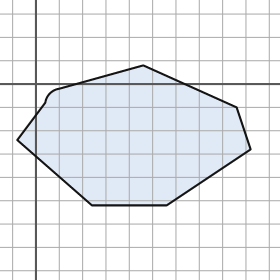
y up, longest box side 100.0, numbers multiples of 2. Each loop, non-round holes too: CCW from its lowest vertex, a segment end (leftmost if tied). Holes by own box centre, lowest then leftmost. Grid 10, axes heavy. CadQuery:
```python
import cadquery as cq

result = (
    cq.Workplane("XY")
    .moveTo(24.0, -52.0)
    .lineTo(56.0, -52.0)
    .lineTo(92.0, -28.0)
    .lineTo(86.0, -10.0)
    .lineTo(46.0, 8.0)
    .lineTo(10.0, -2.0)
    .threePointArc((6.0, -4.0), (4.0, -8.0))
    .lineTo(-8.0, -24.0)
    .close()
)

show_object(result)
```